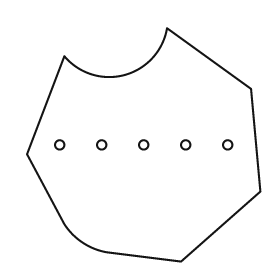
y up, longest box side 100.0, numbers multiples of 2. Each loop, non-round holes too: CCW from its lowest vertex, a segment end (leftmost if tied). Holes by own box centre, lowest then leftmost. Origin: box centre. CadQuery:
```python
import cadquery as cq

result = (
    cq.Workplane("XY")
    .moveTo(16.0, -50.0)
    .lineTo(50.0, -20.0)
    .lineTo(46.0, 24.0)
    .lineTo(10.0, 50.0)
    .threePointArc((-8.0, 30.0), (-34.0, 38.0))
    .lineTo(-50.0, -4.0)
    .lineTo(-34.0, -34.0)
    .threePointArc((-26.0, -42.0), (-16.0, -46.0))
    .close()
    .moveTo(-36.0, 0.0)
    .circle(2.0)
    .moveTo(-18.0, 0.0)
    .circle(2.0)
    .moveTo(0.0, 0.0)
    .circle(2.0)
    .moveTo(18.0, 0.0)
    .circle(2.0)
    .moveTo(36.0, 0.0)
    .circle(2.0)
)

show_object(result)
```